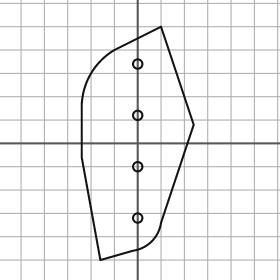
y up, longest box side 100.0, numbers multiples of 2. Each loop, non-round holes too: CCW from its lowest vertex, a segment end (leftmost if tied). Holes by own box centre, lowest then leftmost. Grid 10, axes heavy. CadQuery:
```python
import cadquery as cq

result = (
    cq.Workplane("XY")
    .moveTo(-16.0, -50.0)
    .lineTo(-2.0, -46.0)
    .threePointArc((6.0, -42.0), (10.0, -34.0))
    .lineTo(24.0, 8.0)
    .lineTo(10.0, 50.0)
    .lineTo(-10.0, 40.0)
    .threePointArc((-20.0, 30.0), (-24.0, 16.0))
    .lineTo(-24.0, -6.0)
    .close()
    .moveTo(0.0, -32.0)
    .circle(2.0)
    .moveTo(0.0, -10.0)
    .circle(2.0)
    .moveTo(0.0, 12.0)
    .circle(2.0)
    .moveTo(0.0, 34.0)
    .circle(2.0)
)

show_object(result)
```